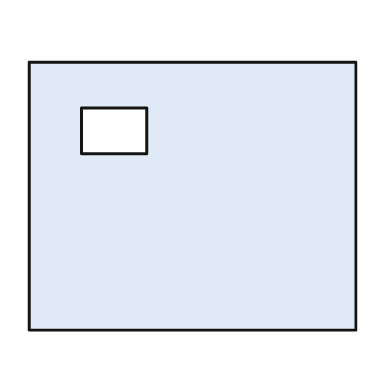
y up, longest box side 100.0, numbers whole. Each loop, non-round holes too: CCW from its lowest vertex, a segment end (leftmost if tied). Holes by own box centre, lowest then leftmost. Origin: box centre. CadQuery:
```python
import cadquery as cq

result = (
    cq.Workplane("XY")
    .moveTo(-50.0, -41.0)
    .lineTo(50.0, -41.0)
    .lineTo(50.0, 41.0)
    .lineTo(-50.0, 41.0)
    .close()
    .moveTo(-34.0, 13.0)
    .lineTo(-14.0, 13.0)
    .lineTo(-14.0, 27.0)
    .lineTo(-34.0, 27.0)
    .close()
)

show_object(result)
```